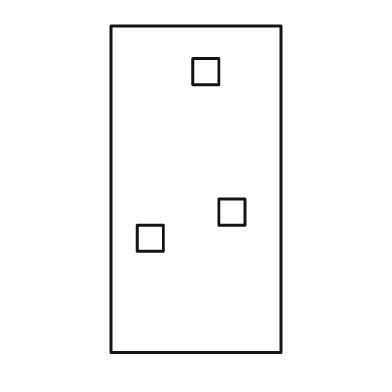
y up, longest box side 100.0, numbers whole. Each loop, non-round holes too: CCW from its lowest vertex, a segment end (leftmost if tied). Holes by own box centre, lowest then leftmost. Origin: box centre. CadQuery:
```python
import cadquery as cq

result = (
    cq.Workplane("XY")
    .moveTo(-26.0, -50.0)
    .lineTo(26.0, -50.0)
    .lineTo(26.0, 50.0)
    .lineTo(-26.0, 50.0)
    .close()
    .moveTo(-18.0, -19.0)
    .lineTo(-10.0, -19.0)
    .lineTo(-10.0, -11.0)
    .lineTo(-18.0, -11.0)
    .close()
    .moveTo(7.0, -11.0)
    .lineTo(15.0, -11.0)
    .lineTo(15.0, -3.0)
    .lineTo(7.0, -3.0)
    .close()
    .moveTo(-1.0, 32.0)
    .lineTo(7.0, 32.0)
    .lineTo(7.0, 40.0)
    .lineTo(-1.0, 40.0)
    .close()
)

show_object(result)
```